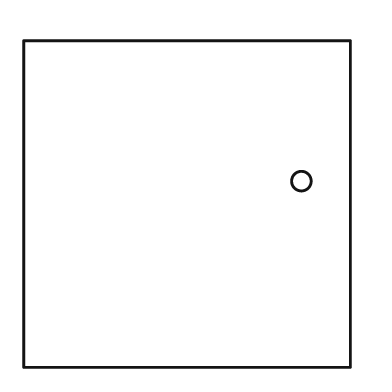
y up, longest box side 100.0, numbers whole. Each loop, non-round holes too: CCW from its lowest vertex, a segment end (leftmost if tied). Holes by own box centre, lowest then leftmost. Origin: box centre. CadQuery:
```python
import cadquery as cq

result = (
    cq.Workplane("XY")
    .moveTo(-50.0, -50.0)
    .lineTo(50.0, -50.0)
    .lineTo(50.0, 50.0)
    .lineTo(-50.0, 50.0)
    .close()
    .moveTo(35.0, 7.0)
    .circle(3.0)
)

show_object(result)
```